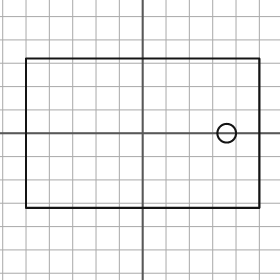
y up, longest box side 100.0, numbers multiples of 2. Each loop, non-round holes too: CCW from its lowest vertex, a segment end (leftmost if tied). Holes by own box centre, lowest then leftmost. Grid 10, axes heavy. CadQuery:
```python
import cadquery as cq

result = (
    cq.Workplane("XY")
    .moveTo(-50.0, -32.0)
    .lineTo(50.0, -32.0)
    .lineTo(50.0, 32.0)
    .lineTo(-50.0, 32.0)
    .close()
    .moveTo(36.0, 0.0)
    .circle(4.0)
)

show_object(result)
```